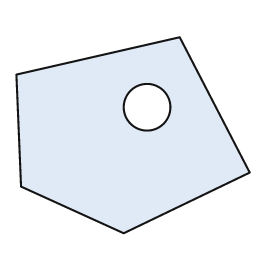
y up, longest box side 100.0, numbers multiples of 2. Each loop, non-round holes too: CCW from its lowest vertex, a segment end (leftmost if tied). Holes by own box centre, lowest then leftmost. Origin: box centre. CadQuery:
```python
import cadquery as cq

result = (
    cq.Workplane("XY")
    .moveTo(-4.0, -42.0)
    .lineTo(50.0, -16.0)
    .lineTo(20.0, 42.0)
    .lineTo(-50.0, 26.0)
    .lineTo(-48.0, -22.0)
    .close()
    .moveTo(6.0, 12.0)
    .circle(10.0)
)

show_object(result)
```